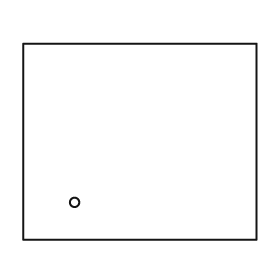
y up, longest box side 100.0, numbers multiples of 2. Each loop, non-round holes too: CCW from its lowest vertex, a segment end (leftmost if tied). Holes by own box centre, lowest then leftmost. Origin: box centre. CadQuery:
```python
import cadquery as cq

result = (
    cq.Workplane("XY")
    .moveTo(-50.0, -42.0)
    .lineTo(50.0, -42.0)
    .lineTo(50.0, 42.0)
    .lineTo(-50.0, 42.0)
    .close()
    .moveTo(-28.0, -26.0)
    .circle(2.0)
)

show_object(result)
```